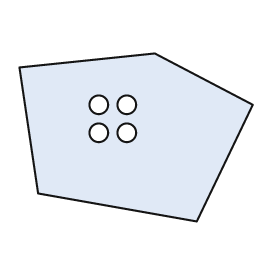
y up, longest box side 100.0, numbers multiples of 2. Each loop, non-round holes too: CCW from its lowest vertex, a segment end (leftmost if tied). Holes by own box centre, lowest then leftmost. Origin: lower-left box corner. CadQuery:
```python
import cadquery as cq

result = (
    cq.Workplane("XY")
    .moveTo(76.0, 0.0)
    .lineTo(100.0, 50.0)
    .lineTo(58.0, 72.0)
    .lineTo(0.0, 66.0)
    .lineTo(8.0, 12.0)
    .close()
    .moveTo(34.0, 38.0)
    .circle(4.0)
    .moveTo(46.0, 38.0)
    .circle(4.0)
    .moveTo(34.0, 50.0)
    .circle(4.0)
    .moveTo(46.0, 50.0)
    .circle(4.0)
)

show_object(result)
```